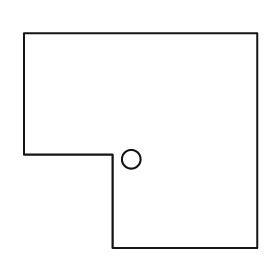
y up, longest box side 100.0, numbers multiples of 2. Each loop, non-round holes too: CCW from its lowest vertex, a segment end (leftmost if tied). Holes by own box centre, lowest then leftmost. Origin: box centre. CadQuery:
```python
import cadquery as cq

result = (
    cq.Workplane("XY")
    .moveTo(-12.0, -46.0)
    .lineTo(50.0, -46.0)
    .lineTo(50.0, 46.0)
    .lineTo(-50.0, 46.0)
    .lineTo(-50.0, -6.0)
    .lineTo(-12.0, -6.0)
    .close()
    .moveTo(-4.0, -8.0)
    .circle(4.0)
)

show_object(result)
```